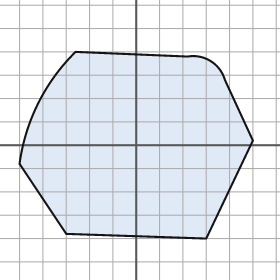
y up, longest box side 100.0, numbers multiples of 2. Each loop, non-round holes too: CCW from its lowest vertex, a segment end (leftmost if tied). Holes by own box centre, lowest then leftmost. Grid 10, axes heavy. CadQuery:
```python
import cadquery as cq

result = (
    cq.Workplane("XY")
    .moveTo(30.0, -40.0)
    .lineTo(50.0, 2.0)
    .lineTo(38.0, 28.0)
    .threePointArc((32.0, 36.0), (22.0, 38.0))
    .lineTo(-26.0, 40.0)
    .threePointArc((-42.0, 18.0), (-50.0, -8.0))
    .lineTo(-30.0, -38.0)
    .close()
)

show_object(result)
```